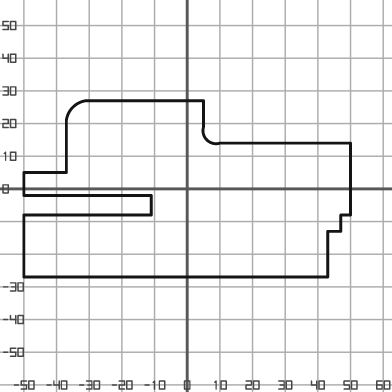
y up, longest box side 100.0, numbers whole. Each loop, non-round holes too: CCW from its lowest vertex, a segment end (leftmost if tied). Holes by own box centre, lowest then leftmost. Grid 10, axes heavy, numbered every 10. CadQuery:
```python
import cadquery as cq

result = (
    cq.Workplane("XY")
    .moveTo(-50.0, -27.0)
    .lineTo(43.0, -27.0)
    .lineTo(43.0, -13.0)
    .lineTo(47.0, -13.0)
    .lineTo(47.0, -8.0)
    .lineTo(50.0, -8.0)
    .lineTo(50.0, 14.0)
    .lineTo(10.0, 14.0)
    .threePointArc((6.0, 15.0), (5.0, 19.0))
    .lineTo(5.0, 27.0)
    .lineTo(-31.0, 27.0)
    .threePointArc((-35.0, 25.0), (-37.0, 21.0))
    .lineTo(-37.0, 5.0)
    .lineTo(-50.0, 5.0)
    .lineTo(-50.0, -2.0)
    .lineTo(-11.0, -2.0)
    .lineTo(-11.0, -8.0)
    .lineTo(-50.0, -8.0)
    .close()
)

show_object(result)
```